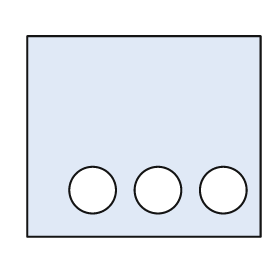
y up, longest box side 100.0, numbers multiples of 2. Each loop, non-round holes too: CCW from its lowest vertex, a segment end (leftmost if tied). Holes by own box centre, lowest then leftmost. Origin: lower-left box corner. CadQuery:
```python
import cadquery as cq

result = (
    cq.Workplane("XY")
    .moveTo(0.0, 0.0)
    .lineTo(100.0, 0.0)
    .lineTo(100.0, 86.0)
    .lineTo(0.0, 86.0)
    .close()
    .moveTo(28.0, 20.0)
    .circle(10.0)
    .moveTo(56.0, 20.0)
    .circle(10.0)
    .moveTo(84.0, 20.0)
    .circle(10.0)
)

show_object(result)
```